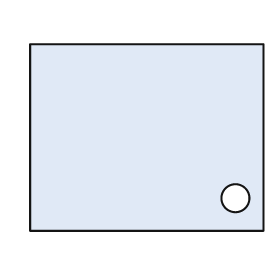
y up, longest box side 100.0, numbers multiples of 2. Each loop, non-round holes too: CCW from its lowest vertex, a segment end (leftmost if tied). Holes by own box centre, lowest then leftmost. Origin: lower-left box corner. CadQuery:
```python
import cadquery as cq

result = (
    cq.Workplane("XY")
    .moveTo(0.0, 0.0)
    .lineTo(100.0, 0.0)
    .lineTo(100.0, 80.0)
    .lineTo(0.0, 80.0)
    .close()
    .moveTo(88.0, 14.0)
    .circle(6.0)
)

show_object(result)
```